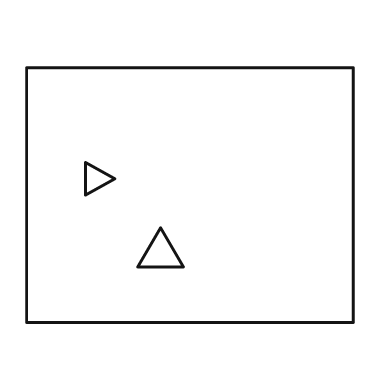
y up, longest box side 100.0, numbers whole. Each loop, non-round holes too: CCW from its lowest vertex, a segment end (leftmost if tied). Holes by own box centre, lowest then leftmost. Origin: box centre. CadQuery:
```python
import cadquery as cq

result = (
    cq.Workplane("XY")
    .moveTo(-50.0, -39.0)
    .lineTo(50.0, -39.0)
    .lineTo(50.0, 39.0)
    .lineTo(-50.0, 39.0)
    .close()
    .moveTo(-16.0, -22.0)
    .lineTo(-2.0, -22.0)
    .lineTo(-9.0, -10.0)
    .close()
    .moveTo(-32.0, 0.0)
    .lineTo(-23.0, 5.0)
    .lineTo(-32.0, 10.0)
    .close()
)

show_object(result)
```